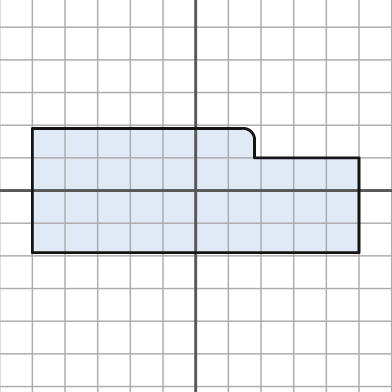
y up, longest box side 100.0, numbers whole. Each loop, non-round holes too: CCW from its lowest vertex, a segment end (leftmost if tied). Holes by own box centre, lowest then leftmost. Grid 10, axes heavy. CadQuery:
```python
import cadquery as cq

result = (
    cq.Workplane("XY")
    .moveTo(-50.0, -19.0)
    .lineTo(50.0, -19.0)
    .lineTo(50.0, 10.0)
    .lineTo(18.0, 10.0)
    .lineTo(18.0, 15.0)
    .threePointArc((17.0, 18.0), (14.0, 19.0))
    .lineTo(-50.0, 19.0)
    .close()
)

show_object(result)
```